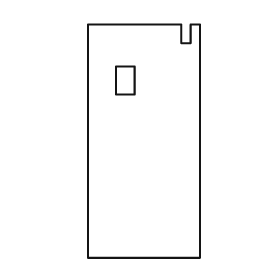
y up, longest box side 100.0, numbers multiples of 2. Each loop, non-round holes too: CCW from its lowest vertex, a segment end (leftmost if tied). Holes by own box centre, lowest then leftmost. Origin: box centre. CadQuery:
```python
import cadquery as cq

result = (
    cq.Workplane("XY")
    .moveTo(-24.0, -50.0)
    .lineTo(24.0, -50.0)
    .lineTo(24.0, 50.0)
    .lineTo(20.0, 50.0)
    .lineTo(20.0, 42.0)
    .lineTo(16.0, 42.0)
    .lineTo(16.0, 50.0)
    .lineTo(-24.0, 50.0)
    .close()
    .moveTo(-12.0, 20.0)
    .lineTo(-4.0, 20.0)
    .lineTo(-4.0, 32.0)
    .lineTo(-12.0, 32.0)
    .close()
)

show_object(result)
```